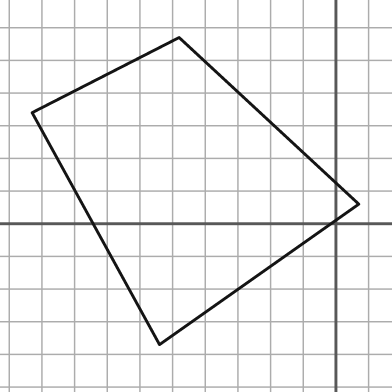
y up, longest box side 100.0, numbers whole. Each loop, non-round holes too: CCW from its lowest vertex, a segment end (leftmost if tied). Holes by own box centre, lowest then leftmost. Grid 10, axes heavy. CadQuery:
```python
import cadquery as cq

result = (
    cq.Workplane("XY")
    .moveTo(-54.0, -37.0)
    .lineTo(7.0, 6.0)
    .lineTo(-48.0, 57.0)
    .lineTo(-93.0, 34.0)
    .close()
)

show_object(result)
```